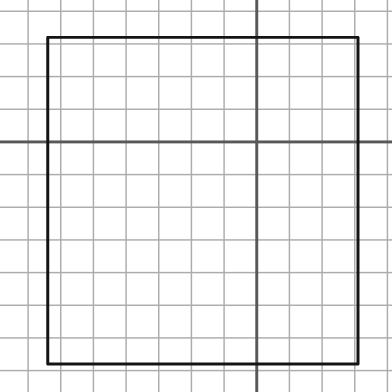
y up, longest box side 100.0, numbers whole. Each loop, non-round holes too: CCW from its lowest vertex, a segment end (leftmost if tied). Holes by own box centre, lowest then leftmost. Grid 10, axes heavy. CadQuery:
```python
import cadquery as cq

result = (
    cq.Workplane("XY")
    .moveTo(-64.0, -68.0)
    .lineTo(31.0, -68.0)
    .lineTo(31.0, 32.0)
    .lineTo(-64.0, 32.0)
    .close()
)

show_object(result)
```